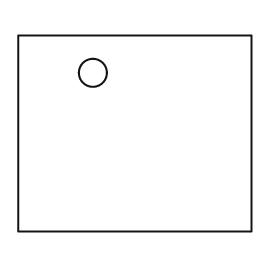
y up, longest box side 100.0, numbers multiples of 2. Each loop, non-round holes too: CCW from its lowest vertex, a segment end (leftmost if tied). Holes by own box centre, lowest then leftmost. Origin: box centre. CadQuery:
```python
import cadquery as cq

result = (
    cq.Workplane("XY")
    .moveTo(-50.0, -42.0)
    .lineTo(50.0, -42.0)
    .lineTo(50.0, 42.0)
    .lineTo(-50.0, 42.0)
    .close()
    .moveTo(-18.0, 26.0)
    .circle(6.0)
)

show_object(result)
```